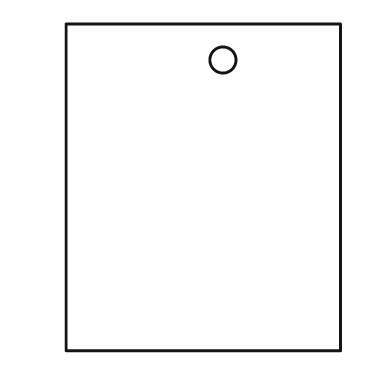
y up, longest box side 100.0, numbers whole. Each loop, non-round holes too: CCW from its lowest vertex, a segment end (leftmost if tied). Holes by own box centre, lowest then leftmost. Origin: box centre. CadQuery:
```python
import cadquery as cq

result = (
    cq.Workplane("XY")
    .moveTo(-42.0, -50.0)
    .lineTo(42.0, -50.0)
    .lineTo(42.0, 50.0)
    .lineTo(-42.0, 50.0)
    .close()
    .moveTo(6.0, 39.0)
    .circle(4.0)
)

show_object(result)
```